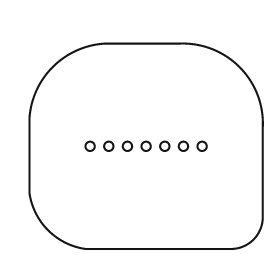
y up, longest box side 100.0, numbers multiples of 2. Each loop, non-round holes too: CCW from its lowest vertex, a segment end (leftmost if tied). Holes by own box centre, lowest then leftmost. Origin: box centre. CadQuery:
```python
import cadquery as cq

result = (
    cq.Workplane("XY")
    .moveTo(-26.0, -44.0)
    .lineTo(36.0, -44.0)
    .threePointArc((46.0, -40.0), (50.0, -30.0))
    .lineTo(50.0, 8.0)
    .threePointArc((40.0, 34.0), (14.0, 44.0))
    .lineTo(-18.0, 44.0)
    .threePointArc((-40.0, 34.0), (-50.0, 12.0))
    .lineTo(-50.0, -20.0)
    .threePointArc((-42.0, -36.0), (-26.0, -44.0))
    .close()
    .moveTo(-24.0, 0.0)
    .circle(2.0)
    .moveTo(-16.0, 0.0)
    .circle(2.0)
    .moveTo(-8.0, 0.0)
    .circle(2.0)
    .moveTo(0.0, 0.0)
    .circle(2.0)
    .moveTo(8.0, 0.0)
    .circle(2.0)
    .moveTo(16.0, 0.0)
    .circle(2.0)
    .moveTo(24.0, 0.0)
    .circle(2.0)
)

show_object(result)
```